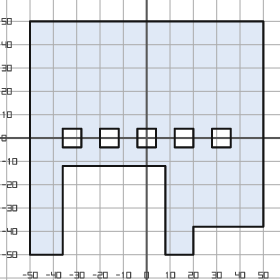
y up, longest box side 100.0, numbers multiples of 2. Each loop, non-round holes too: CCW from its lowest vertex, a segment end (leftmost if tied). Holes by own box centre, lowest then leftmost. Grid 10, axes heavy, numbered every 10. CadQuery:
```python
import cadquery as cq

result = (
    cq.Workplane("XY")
    .moveTo(-50.0, -50.0)
    .lineTo(-36.0, -50.0)
    .lineTo(-36.0, -12.0)
    .lineTo(8.0, -12.0)
    .lineTo(8.0, -50.0)
    .lineTo(20.0, -50.0)
    .lineTo(20.0, -38.0)
    .lineTo(50.0, -38.0)
    .lineTo(50.0, 50.0)
    .lineTo(-50.0, 50.0)
    .close()
    .moveTo(-36.0, -4.0)
    .lineTo(-28.0, -4.0)
    .lineTo(-28.0, 4.0)
    .lineTo(-36.0, 4.0)
    .close()
    .moveTo(-20.0, -4.0)
    .lineTo(-12.0, -4.0)
    .lineTo(-12.0, 4.0)
    .lineTo(-20.0, 4.0)
    .close()
    .moveTo(-4.0, -4.0)
    .lineTo(4.0, -4.0)
    .lineTo(4.0, 4.0)
    .lineTo(-4.0, 4.0)
    .close()
    .moveTo(12.0, -4.0)
    .lineTo(20.0, -4.0)
    .lineTo(20.0, 4.0)
    .lineTo(12.0, 4.0)
    .close()
    .moveTo(28.0, -4.0)
    .lineTo(36.0, -4.0)
    .lineTo(36.0, 4.0)
    .lineTo(28.0, 4.0)
    .close()
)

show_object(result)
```